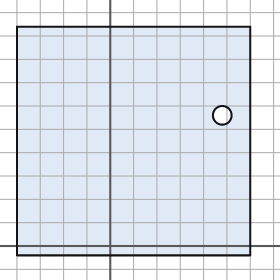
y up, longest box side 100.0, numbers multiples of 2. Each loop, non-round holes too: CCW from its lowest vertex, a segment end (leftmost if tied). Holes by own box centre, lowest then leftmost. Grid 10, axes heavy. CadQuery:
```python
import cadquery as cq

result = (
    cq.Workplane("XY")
    .moveTo(-40.0, -4.0)
    .lineTo(60.0, -4.0)
    .lineTo(60.0, 94.0)
    .lineTo(-40.0, 94.0)
    .close()
    .moveTo(48.0, 56.0)
    .circle(4.0)
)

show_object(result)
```